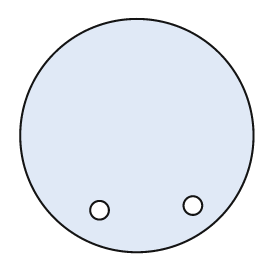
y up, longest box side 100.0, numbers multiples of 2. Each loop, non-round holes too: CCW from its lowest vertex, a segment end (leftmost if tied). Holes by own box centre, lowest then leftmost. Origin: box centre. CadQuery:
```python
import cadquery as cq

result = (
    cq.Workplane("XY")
    .moveTo(0.0, 0.0)
    .circle(50.0)
    .moveTo(-16.0, -32.0)
    .circle(4.0)
    .moveTo(24.0, -30.0)
    .circle(4.0)
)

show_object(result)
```